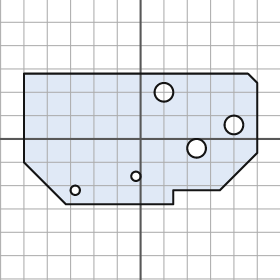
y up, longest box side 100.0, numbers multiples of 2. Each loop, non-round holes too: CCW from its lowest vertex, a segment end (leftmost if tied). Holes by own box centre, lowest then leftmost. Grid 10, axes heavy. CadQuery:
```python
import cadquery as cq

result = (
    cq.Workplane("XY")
    .moveTo(-32.0, -28.0)
    .lineTo(14.0, -28.0)
    .lineTo(14.0, -22.0)
    .lineTo(34.0, -22.0)
    .lineTo(50.0, -6.0)
    .lineTo(50.0, 24.0)
    .lineTo(46.0, 28.0)
    .lineTo(-50.0, 28.0)
    .lineTo(-50.0, -10.0)
    .close()
    .moveTo(-28.0, -22.0)
    .circle(2.0)
    .moveTo(-2.0, -16.0)
    .circle(2.0)
    .moveTo(24.0, -4.0)
    .circle(4.0)
    .moveTo(40.0, 6.0)
    .circle(4.0)
    .moveTo(10.0, 20.0)
    .circle(4.0)
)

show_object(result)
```